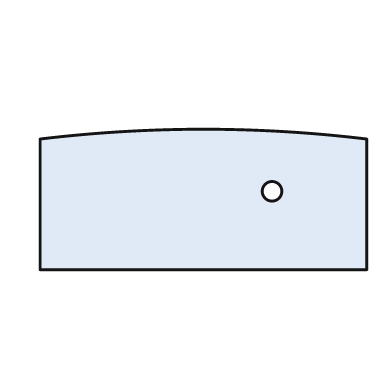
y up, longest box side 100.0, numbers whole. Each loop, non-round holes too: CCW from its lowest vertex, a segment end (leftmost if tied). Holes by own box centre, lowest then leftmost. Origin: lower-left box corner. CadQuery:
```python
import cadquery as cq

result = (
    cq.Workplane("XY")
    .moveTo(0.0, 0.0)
    .lineTo(100.0, 0.0)
    .lineTo(100.0, 40.0)
    .threePointArc((50.0, 43.0), (0.0, 40.0))
    .close()
    .moveTo(71.0, 24.0)
    .circle(3.0)
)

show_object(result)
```